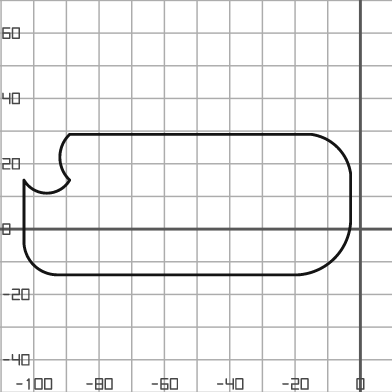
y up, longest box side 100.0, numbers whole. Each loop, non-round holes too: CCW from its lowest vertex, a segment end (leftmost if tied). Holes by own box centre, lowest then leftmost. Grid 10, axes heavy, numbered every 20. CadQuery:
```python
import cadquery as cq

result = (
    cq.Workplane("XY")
    .moveTo(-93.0, -14.0)
    .lineTo(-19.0, -14.0)
    .threePointArc((-8.0, -9.0), (-3.0, 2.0))
    .lineTo(-3.0, 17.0)
    .threePointArc((-7.0, 25.0), (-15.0, 29.0))
    .lineTo(-89.0, 29.0)
    .threePointArc((-92.0, 22.0), (-89.0, 15.0))
    .threePointArc((-96.0, 11.0), (-103.0, 15.0))
    .lineTo(-103.0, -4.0)
    .threePointArc((-100.0, -11.0), (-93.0, -14.0))
    .close()
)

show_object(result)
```